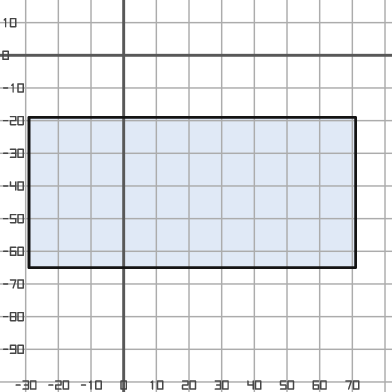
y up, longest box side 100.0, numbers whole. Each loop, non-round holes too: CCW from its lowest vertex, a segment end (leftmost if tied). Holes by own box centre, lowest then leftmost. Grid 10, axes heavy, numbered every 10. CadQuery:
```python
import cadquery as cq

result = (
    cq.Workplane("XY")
    .moveTo(-29.0, -65.0)
    .lineTo(71.0, -65.0)
    .lineTo(71.0, -19.0)
    .lineTo(-29.0, -19.0)
    .close()
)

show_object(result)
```